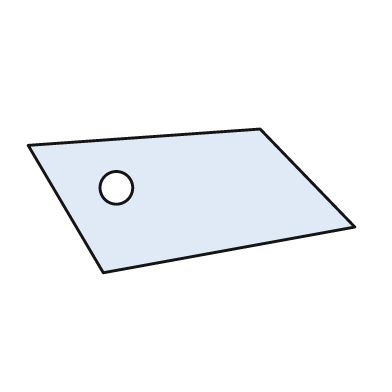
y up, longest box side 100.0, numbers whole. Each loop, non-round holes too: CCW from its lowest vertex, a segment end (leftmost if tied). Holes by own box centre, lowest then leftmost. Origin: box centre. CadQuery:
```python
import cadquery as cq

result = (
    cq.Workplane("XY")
    .moveTo(-27.0, -22.0)
    .lineTo(50.0, -8.0)
    .lineTo(21.0, 22.0)
    .lineTo(-50.0, 17.0)
    .close()
    .moveTo(-23.0, 4.0)
    .circle(5.0)
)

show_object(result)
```